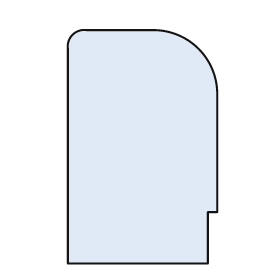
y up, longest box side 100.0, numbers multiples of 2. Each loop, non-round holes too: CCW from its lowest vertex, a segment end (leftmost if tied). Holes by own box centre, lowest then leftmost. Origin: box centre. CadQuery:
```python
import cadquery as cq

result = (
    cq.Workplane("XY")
    .moveTo(-32.0, -50.0)
    .lineTo(28.0, -50.0)
    .lineTo(28.0, -28.0)
    .lineTo(32.0, -28.0)
    .lineTo(32.0, 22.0)
    .threePointArc((24.0, 42.0), (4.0, 50.0))
    .lineTo(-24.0, 50.0)
    .threePointArc((-30.0, 48.0), (-32.0, 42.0))
    .close()
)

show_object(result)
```